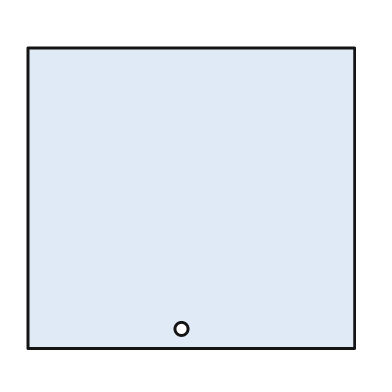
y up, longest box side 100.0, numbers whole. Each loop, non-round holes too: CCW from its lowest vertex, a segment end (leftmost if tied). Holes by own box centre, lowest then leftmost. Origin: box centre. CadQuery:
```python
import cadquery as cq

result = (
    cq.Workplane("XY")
    .moveTo(-50.0, -46.0)
    .lineTo(50.0, -46.0)
    .lineTo(50.0, 46.0)
    .lineTo(-50.0, 46.0)
    .close()
    .moveTo(-3.0, -40.0)
    .circle(2.0)
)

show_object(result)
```